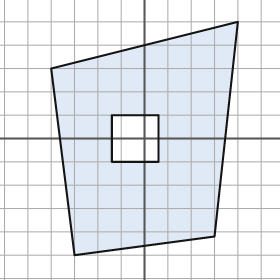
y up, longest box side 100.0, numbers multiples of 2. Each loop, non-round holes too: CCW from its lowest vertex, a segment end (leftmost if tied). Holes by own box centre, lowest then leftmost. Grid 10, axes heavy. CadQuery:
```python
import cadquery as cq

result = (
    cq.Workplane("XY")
    .moveTo(-30.0, -50.0)
    .lineTo(30.0, -42.0)
    .lineTo(40.0, 50.0)
    .lineTo(-40.0, 30.0)
    .close()
    .moveTo(-14.0, -10.0)
    .lineTo(6.0, -10.0)
    .lineTo(6.0, 10.0)
    .lineTo(-14.0, 10.0)
    .close()
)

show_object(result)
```